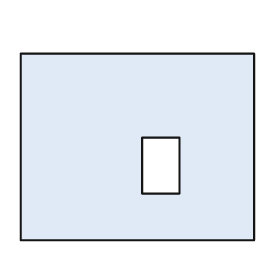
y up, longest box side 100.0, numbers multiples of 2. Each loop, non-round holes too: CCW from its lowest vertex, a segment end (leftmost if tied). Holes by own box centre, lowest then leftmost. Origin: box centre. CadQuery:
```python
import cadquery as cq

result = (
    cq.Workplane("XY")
    .moveTo(-50.0, -40.0)
    .lineTo(50.0, -40.0)
    .lineTo(50.0, 40.0)
    .lineTo(-50.0, 40.0)
    .close()
    .moveTo(2.0, -20.0)
    .lineTo(18.0, -20.0)
    .lineTo(18.0, 4.0)
    .lineTo(2.0, 4.0)
    .close()
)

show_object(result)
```